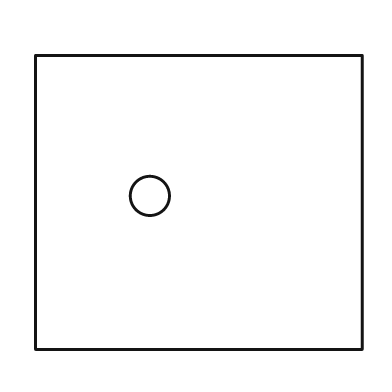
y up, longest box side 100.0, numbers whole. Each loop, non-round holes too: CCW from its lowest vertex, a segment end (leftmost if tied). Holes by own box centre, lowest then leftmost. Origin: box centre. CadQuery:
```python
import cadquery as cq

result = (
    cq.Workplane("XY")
    .moveTo(-50.0, -45.0)
    .lineTo(50.0, -45.0)
    .lineTo(50.0, 45.0)
    .lineTo(-50.0, 45.0)
    .close()
    .moveTo(-15.0, 2.0)
    .circle(6.0)
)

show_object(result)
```